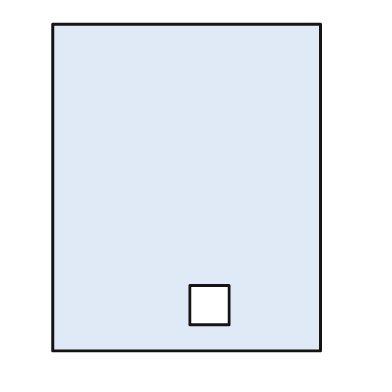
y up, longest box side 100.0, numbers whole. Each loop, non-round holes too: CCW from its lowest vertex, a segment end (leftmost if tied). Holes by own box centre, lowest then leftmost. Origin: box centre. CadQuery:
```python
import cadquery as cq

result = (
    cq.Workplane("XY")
    .moveTo(-41.0, -50.0)
    .lineTo(41.0, -50.0)
    .lineTo(41.0, 50.0)
    .lineTo(-41.0, 50.0)
    .close()
    .moveTo(1.0, -42.0)
    .lineTo(13.0, -42.0)
    .lineTo(13.0, -30.0)
    .lineTo(1.0, -30.0)
    .close()
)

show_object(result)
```